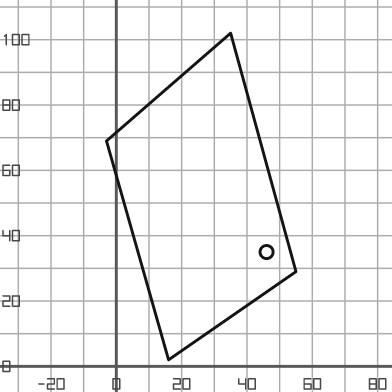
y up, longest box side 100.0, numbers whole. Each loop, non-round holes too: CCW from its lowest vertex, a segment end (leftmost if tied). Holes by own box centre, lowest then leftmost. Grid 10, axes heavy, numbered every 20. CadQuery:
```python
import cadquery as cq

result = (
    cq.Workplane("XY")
    .moveTo(16.0, 2.0)
    .lineTo(55.0, 29.0)
    .lineTo(35.0, 102.0)
    .lineTo(-3.0, 69.0)
    .close()
    .moveTo(46.0, 35.0)
    .circle(2.0)
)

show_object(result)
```